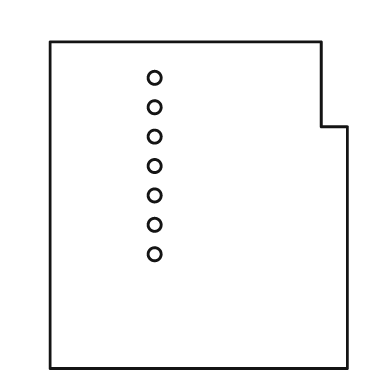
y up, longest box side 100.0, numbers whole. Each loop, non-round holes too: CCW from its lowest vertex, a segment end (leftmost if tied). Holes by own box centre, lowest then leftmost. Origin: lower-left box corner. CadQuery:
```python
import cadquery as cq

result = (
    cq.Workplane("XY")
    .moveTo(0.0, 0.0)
    .lineTo(91.0, 0.0)
    .lineTo(91.0, 74.0)
    .lineTo(83.0, 74.0)
    .lineTo(83.0, 100.0)
    .lineTo(0.0, 100.0)
    .close()
    .moveTo(32.0, 35.0)
    .circle(2.0)
    .moveTo(32.0, 44.0)
    .circle(2.0)
    .moveTo(32.0, 53.0)
    .circle(2.0)
    .moveTo(32.0, 62.0)
    .circle(2.0)
    .moveTo(32.0, 71.0)
    .circle(2.0)
    .moveTo(32.0, 80.0)
    .circle(2.0)
    .moveTo(32.0, 89.0)
    .circle(2.0)
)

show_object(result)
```